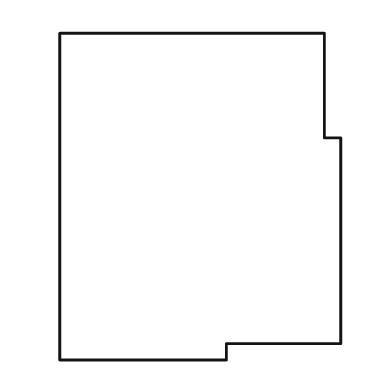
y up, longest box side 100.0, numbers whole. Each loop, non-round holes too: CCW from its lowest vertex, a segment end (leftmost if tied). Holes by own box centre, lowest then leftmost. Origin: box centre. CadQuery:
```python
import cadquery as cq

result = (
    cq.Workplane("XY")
    .moveTo(-43.0, -50.0)
    .lineTo(8.0, -50.0)
    .lineTo(8.0, -45.0)
    .lineTo(43.0, -45.0)
    .lineTo(43.0, 18.0)
    .lineTo(38.0, 18.0)
    .lineTo(38.0, 50.0)
    .lineTo(-43.0, 50.0)
    .close()
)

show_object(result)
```